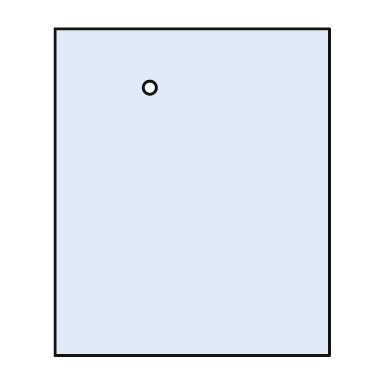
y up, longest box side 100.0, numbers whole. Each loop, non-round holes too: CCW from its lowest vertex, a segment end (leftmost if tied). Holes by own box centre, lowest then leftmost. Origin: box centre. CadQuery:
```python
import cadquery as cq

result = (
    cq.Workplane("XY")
    .moveTo(-42.0, -50.0)
    .lineTo(42.0, -50.0)
    .lineTo(42.0, 50.0)
    .lineTo(-42.0, 50.0)
    .close()
    .moveTo(-13.0, 32.0)
    .circle(2.0)
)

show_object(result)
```